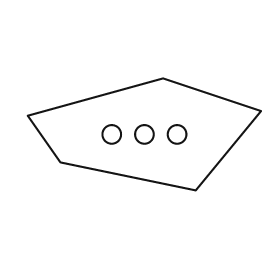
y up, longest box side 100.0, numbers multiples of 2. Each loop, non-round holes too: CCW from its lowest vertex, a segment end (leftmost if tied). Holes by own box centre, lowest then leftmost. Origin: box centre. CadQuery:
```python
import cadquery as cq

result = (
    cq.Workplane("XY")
    .moveTo(22.0, -24.0)
    .lineTo(50.0, 10.0)
    .lineTo(8.0, 24.0)
    .lineTo(-50.0, 8.0)
    .lineTo(-36.0, -12.0)
    .close()
    .moveTo(-14.0, 0.0)
    .circle(4.0)
    .moveTo(0.0, 0.0)
    .circle(4.0)
    .moveTo(14.0, 0.0)
    .circle(4.0)
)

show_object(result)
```